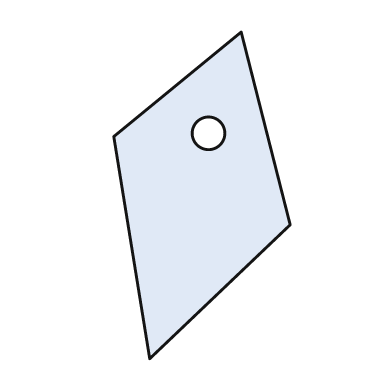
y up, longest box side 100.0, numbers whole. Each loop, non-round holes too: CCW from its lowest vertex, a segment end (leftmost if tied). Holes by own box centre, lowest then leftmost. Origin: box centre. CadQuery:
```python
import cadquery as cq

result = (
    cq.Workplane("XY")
    .moveTo(-16.0, -50.0)
    .lineTo(27.0, -9.0)
    .lineTo(12.0, 50.0)
    .lineTo(-27.0, 18.0)
    .close()
    .moveTo(2.0, 19.0)
    .circle(5.0)
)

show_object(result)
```